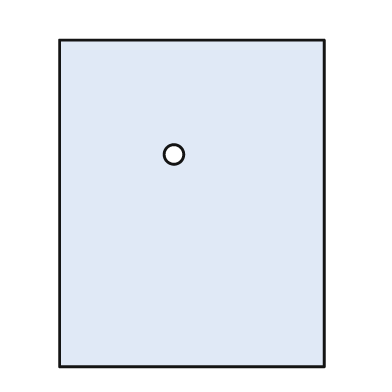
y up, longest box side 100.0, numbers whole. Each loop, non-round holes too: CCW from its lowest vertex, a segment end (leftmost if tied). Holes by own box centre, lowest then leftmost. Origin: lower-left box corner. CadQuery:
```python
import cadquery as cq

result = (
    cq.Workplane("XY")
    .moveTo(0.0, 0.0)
    .lineTo(81.0, 0.0)
    .lineTo(81.0, 100.0)
    .lineTo(0.0, 100.0)
    .close()
    .moveTo(35.0, 65.0)
    .circle(3.0)
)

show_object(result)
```